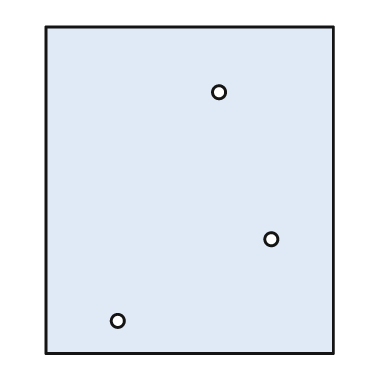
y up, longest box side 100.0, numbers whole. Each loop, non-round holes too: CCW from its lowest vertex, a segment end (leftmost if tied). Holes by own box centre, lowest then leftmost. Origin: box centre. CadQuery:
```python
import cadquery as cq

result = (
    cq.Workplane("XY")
    .moveTo(-44.0, -50.0)
    .lineTo(44.0, -50.0)
    .lineTo(44.0, 50.0)
    .lineTo(-44.0, 50.0)
    .close()
    .moveTo(-22.0, -40.0)
    .circle(2.0)
    .moveTo(25.0, -15.0)
    .circle(2.0)
    .moveTo(9.0, 30.0)
    .circle(2.0)
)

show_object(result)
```